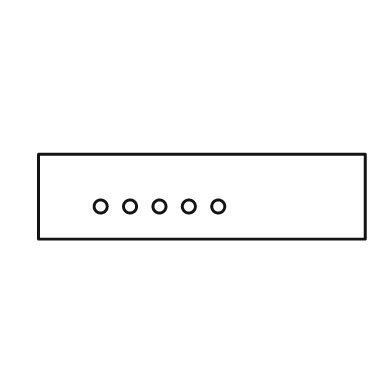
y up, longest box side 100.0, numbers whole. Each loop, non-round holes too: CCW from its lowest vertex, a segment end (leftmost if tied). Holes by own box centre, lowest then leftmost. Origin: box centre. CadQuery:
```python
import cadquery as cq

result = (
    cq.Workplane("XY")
    .moveTo(-50.0, -13.0)
    .lineTo(50.0, -13.0)
    .lineTo(50.0, 13.0)
    .lineTo(-50.0, 13.0)
    .close()
    .moveTo(-31.0, -3.0)
    .circle(2.0)
    .moveTo(-22.0, -3.0)
    .circle(2.0)
    .moveTo(-13.0, -3.0)
    .circle(2.0)
    .moveTo(-4.0, -3.0)
    .circle(2.0)
    .moveTo(5.0, -3.0)
    .circle(2.0)
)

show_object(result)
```